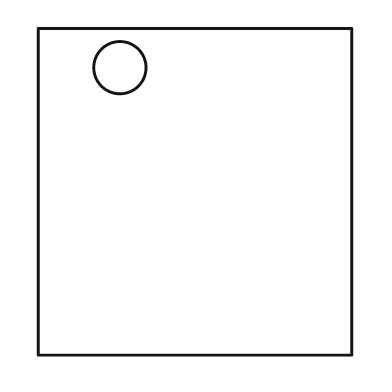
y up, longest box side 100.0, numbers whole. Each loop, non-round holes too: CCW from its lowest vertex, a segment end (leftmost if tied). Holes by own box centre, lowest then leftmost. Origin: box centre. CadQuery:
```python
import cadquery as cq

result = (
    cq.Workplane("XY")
    .moveTo(-48.0, -50.0)
    .lineTo(48.0, -50.0)
    .lineTo(48.0, 50.0)
    .lineTo(-48.0, 50.0)
    .close()
    .moveTo(-23.0, 38.0)
    .circle(8.0)
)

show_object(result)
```